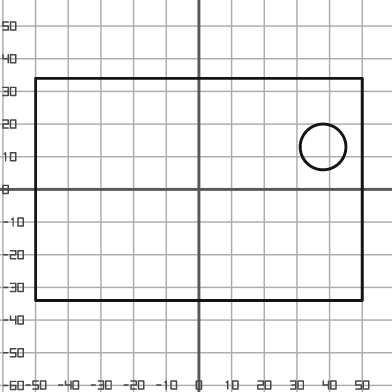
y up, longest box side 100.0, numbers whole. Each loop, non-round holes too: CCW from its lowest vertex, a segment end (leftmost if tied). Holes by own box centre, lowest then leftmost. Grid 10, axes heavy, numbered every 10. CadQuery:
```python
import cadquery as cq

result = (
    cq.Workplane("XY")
    .moveTo(-50.0, -34.0)
    .lineTo(50.0, -34.0)
    .lineTo(50.0, 34.0)
    .lineTo(-50.0, 34.0)
    .close()
    .moveTo(38.0, 13.0)
    .circle(7.0)
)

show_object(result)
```